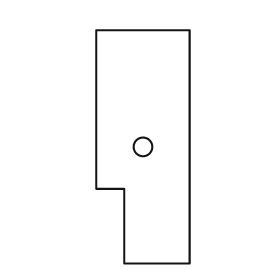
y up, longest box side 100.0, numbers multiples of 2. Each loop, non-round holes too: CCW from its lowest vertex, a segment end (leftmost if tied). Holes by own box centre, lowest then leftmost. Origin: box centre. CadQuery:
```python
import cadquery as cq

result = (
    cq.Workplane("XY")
    .moveTo(-8.0, -50.0)
    .lineTo(20.0, -50.0)
    .lineTo(20.0, 50.0)
    .lineTo(-20.0, 50.0)
    .lineTo(-20.0, -18.0)
    .lineTo(-8.0, -18.0)
    .close()
    .moveTo(0.0, 0.0)
    .circle(4.0)
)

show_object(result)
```